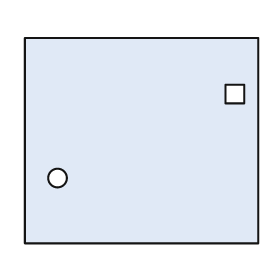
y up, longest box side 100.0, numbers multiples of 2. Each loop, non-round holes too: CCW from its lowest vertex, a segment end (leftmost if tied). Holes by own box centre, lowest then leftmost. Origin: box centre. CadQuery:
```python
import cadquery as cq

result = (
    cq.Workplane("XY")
    .moveTo(-50.0, -44.0)
    .lineTo(50.0, -44.0)
    .lineTo(50.0, 44.0)
    .lineTo(-50.0, 44.0)
    .close()
    .moveTo(-36.0, -16.0)
    .circle(4.0)
    .moveTo(36.0, 16.0)
    .lineTo(44.0, 16.0)
    .lineTo(44.0, 24.0)
    .lineTo(36.0, 24.0)
    .close()
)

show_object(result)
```